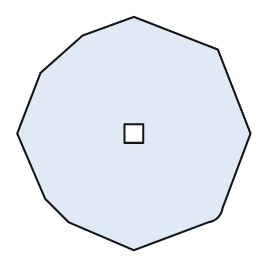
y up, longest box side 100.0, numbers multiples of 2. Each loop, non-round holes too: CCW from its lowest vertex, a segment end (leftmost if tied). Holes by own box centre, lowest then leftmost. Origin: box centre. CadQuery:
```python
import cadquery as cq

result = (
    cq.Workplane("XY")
    .moveTo(0.0, -50.0)
    .lineTo(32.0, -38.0)
    .threePointArc((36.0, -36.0), (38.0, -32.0))
    .lineTo(50.0, 0.0)
    .lineTo(36.0, 36.0)
    .lineTo(0.0, 50.0)
    .lineTo(-22.0, 42.0)
    .lineTo(-40.0, 26.0)
    .lineTo(-50.0, 0.0)
    .lineTo(-38.0, -28.0)
    .lineTo(-28.0, -38.0)
    .close()
    .moveTo(-4.0, -4.0)
    .lineTo(4.0, -4.0)
    .lineTo(4.0, 4.0)
    .lineTo(-4.0, 4.0)
    .close()
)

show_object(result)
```